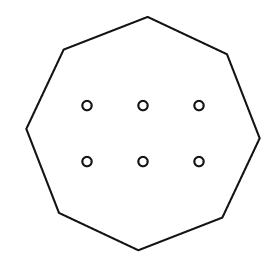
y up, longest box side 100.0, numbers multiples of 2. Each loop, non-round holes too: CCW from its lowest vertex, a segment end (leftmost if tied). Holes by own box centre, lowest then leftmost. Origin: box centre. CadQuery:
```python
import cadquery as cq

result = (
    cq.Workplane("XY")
    .moveTo(-2.0, -50.0)
    .lineTo(34.0, -36.0)
    .lineTo(50.0, -2.0)
    .lineTo(36.0, 34.0)
    .lineTo(2.0, 50.0)
    .lineTo(-34.0, 36.0)
    .lineTo(-50.0, 2.0)
    .lineTo(-36.0, -34.0)
    .close()
    .moveTo(-24.0, -12.0)
    .circle(2.0)
    .moveTo(0.0, -12.0)
    .circle(2.0)
    .moveTo(24.0, -12.0)
    .circle(2.0)
    .moveTo(-24.0, 12.0)
    .circle(2.0)
    .moveTo(0.0, 12.0)
    .circle(2.0)
    .moveTo(24.0, 12.0)
    .circle(2.0)
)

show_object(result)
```